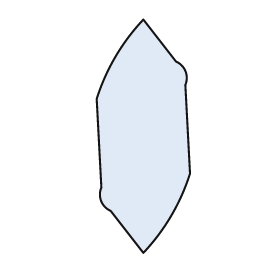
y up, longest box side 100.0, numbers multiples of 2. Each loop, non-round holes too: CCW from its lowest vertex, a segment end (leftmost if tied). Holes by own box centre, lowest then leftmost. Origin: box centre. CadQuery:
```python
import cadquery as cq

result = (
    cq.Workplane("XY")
    .moveTo(0.0, -50.0)
    .threePointArc((12.0, -34.0), (20.0, -16.0))
    .lineTo(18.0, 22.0)
    .threePointArc((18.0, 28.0), (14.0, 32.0))
    .lineTo(0.0, 50.0)
    .threePointArc((-12.0, 34.0), (-20.0, 16.0))
    .lineTo(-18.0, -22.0)
    .threePointArc((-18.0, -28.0), (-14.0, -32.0))
    .close()
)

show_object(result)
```